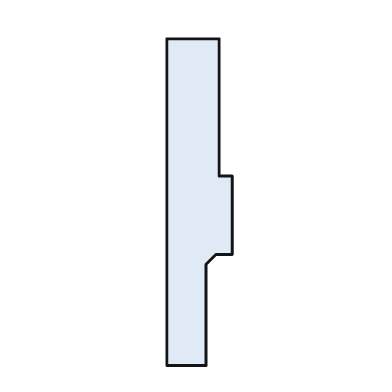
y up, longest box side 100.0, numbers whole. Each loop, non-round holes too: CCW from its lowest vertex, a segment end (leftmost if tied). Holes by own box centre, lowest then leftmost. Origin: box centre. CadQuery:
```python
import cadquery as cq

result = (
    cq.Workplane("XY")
    .moveTo(-10.0, -50.0)
    .lineTo(2.0, -50.0)
    .lineTo(2.0, -19.0)
    .lineTo(5.0, -16.0)
    .lineTo(10.0, -16.0)
    .lineTo(10.0, 8.0)
    .lineTo(6.0, 8.0)
    .lineTo(6.0, 50.0)
    .lineTo(-10.0, 50.0)
    .close()
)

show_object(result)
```